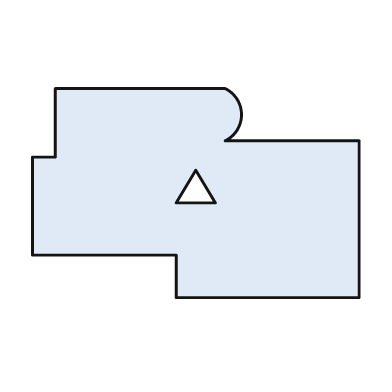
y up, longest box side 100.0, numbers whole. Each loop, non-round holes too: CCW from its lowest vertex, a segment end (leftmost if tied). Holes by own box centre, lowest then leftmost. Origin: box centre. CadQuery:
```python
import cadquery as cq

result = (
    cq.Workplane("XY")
    .moveTo(-6.0, -32.0)
    .lineTo(50.0, -32.0)
    .lineTo(50.0, 16.0)
    .lineTo(9.0, 16.0)
    .threePointArc((14.0, 24.0), (9.0, 32.0))
    .lineTo(-43.0, 32.0)
    .lineTo(-43.0, 11.0)
    .lineTo(-50.0, 11.0)
    .lineTo(-50.0, -19.0)
    .lineTo(-6.0, -19.0)
    .close()
    .moveTo(-6.0, -3.0)
    .lineTo(6.0, -3.0)
    .lineTo(0.0, 7.0)
    .close()
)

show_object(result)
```